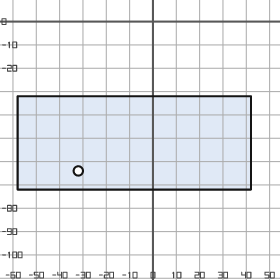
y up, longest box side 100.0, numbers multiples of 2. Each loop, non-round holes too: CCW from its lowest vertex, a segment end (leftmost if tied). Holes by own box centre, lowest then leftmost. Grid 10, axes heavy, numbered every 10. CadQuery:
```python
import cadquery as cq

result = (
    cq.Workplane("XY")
    .moveTo(-58.0, -72.0)
    .lineTo(42.0, -72.0)
    .lineTo(42.0, -32.0)
    .lineTo(-58.0, -32.0)
    .close()
    .moveTo(-32.0, -64.0)
    .circle(2.0)
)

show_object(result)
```